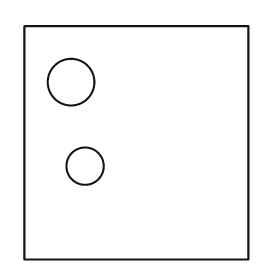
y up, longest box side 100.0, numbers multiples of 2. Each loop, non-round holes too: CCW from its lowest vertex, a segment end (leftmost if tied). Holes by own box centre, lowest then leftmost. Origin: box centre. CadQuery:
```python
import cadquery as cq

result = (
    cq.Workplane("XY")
    .moveTo(-48.0, -50.0)
    .lineTo(48.0, -50.0)
    .lineTo(48.0, 50.0)
    .lineTo(-48.0, 50.0)
    .close()
    .moveTo(-22.0, -10.0)
    .circle(8.0)
    .moveTo(-28.0, 26.0)
    .circle(10.0)
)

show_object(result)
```